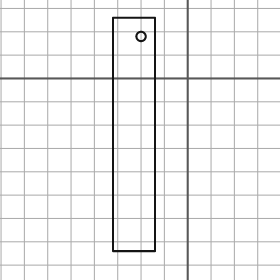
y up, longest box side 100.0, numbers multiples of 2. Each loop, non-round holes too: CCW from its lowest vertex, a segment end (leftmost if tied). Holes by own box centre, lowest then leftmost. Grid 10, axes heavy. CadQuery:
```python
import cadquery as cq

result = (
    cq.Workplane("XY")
    .moveTo(-32.0, -74.0)
    .lineTo(-14.0, -74.0)
    .lineTo(-14.0, 26.0)
    .lineTo(-32.0, 26.0)
    .close()
    .moveTo(-20.0, 18.0)
    .circle(2.0)
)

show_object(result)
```